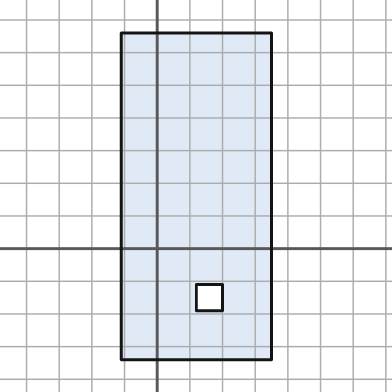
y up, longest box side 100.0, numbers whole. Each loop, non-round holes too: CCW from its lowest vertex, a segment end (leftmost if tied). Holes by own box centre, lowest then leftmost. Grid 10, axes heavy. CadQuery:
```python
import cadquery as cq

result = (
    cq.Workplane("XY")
    .moveTo(-11.0, -34.0)
    .lineTo(35.0, -34.0)
    .lineTo(35.0, 66.0)
    .lineTo(-11.0, 66.0)
    .close()
    .moveTo(12.0, -19.0)
    .lineTo(20.0, -19.0)
    .lineTo(20.0, -11.0)
    .lineTo(12.0, -11.0)
    .close()
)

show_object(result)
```